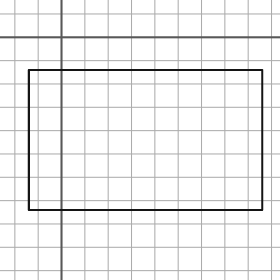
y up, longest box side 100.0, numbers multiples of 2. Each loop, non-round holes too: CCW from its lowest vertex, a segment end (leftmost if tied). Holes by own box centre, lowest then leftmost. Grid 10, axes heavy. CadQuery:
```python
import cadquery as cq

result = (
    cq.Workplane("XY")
    .moveTo(-14.0, -74.0)
    .lineTo(86.0, -74.0)
    .lineTo(86.0, -14.0)
    .lineTo(-14.0, -14.0)
    .close()
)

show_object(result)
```